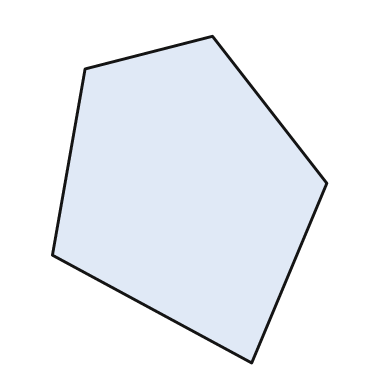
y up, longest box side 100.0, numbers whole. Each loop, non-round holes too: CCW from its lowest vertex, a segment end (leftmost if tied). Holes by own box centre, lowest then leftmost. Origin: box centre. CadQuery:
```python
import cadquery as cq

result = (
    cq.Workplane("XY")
    .moveTo(19.0, -50.0)
    .lineTo(42.0, 5.0)
    .lineTo(7.0, 50.0)
    .lineTo(-32.0, 40.0)
    .lineTo(-42.0, -17.0)
    .close()
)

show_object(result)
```